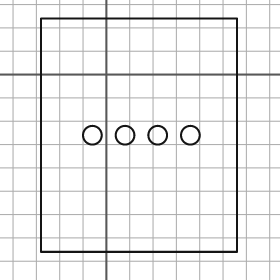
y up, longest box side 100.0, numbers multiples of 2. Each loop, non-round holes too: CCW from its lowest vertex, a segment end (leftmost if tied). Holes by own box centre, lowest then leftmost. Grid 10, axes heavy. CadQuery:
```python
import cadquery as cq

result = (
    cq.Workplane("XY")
    .moveTo(-28.0, -76.0)
    .lineTo(56.0, -76.0)
    .lineTo(56.0, 24.0)
    .lineTo(-28.0, 24.0)
    .close()
    .moveTo(-6.0, -26.0)
    .circle(4.0)
    .moveTo(8.0, -26.0)
    .circle(4.0)
    .moveTo(22.0, -26.0)
    .circle(4.0)
    .moveTo(36.0, -26.0)
    .circle(4.0)
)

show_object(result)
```